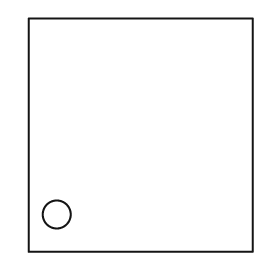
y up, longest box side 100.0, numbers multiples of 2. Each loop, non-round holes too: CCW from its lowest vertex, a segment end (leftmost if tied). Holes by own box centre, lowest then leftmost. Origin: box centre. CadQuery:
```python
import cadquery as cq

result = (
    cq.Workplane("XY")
    .moveTo(-48.0, -50.0)
    .lineTo(48.0, -50.0)
    .lineTo(48.0, 50.0)
    .lineTo(-48.0, 50.0)
    .close()
    .moveTo(-36.0, -34.0)
    .circle(6.0)
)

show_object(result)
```